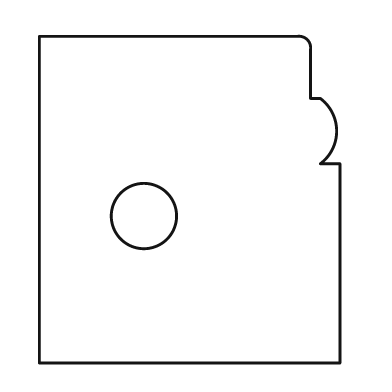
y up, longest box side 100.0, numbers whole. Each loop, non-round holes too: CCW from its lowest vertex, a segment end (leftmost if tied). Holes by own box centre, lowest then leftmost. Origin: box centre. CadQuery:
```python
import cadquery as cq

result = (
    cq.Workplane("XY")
    .moveTo(-46.0, -50.0)
    .lineTo(46.0, -50.0)
    .lineTo(46.0, 11.0)
    .lineTo(40.0, 11.0)
    .threePointArc((45.0, 21.0), (40.0, 31.0))
    .lineTo(37.0, 31.0)
    .lineTo(37.0, 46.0)
    .threePointArc((36.0, 49.0), (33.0, 50.0))
    .lineTo(-46.0, 50.0)
    .close()
    .moveTo(-14.0, -5.0)
    .circle(10.0)
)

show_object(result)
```